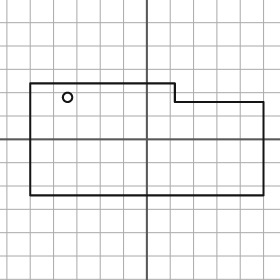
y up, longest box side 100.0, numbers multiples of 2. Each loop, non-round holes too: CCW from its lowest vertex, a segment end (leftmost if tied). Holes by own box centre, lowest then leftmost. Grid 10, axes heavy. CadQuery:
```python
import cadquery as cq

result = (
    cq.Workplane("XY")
    .moveTo(-50.0, -24.0)
    .lineTo(50.0, -24.0)
    .lineTo(50.0, 16.0)
    .lineTo(12.0, 16.0)
    .lineTo(12.0, 24.0)
    .lineTo(-50.0, 24.0)
    .close()
    .moveTo(-34.0, 18.0)
    .circle(2.0)
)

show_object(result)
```